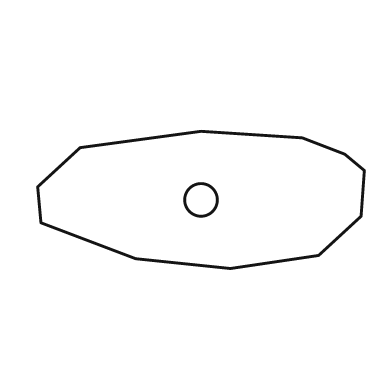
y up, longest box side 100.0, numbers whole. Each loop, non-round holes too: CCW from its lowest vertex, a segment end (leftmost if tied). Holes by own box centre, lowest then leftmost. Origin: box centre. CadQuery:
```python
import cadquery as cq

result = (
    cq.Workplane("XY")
    .moveTo(9.0, -21.0)
    .lineTo(36.0, -17.0)
    .lineTo(49.0, -5.0)
    .lineTo(50.0, 9.0)
    .lineTo(44.0, 14.0)
    .lineTo(31.0, 19.0)
    .lineTo(0.0, 21.0)
    .lineTo(-37.0, 16.0)
    .lineTo(-50.0, 4.0)
    .lineTo(-49.0, -7.0)
    .lineTo(-20.0, -18.0)
    .close()
    .moveTo(0.0, 0.0)
    .circle(5.0)
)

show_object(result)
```